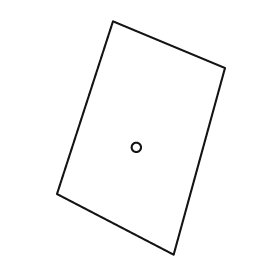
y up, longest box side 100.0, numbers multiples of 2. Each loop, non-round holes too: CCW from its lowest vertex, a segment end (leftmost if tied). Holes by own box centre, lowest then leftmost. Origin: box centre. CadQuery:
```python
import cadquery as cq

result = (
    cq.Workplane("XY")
    .moveTo(14.0, -50.0)
    .lineTo(36.0, 30.0)
    .lineTo(-12.0, 50.0)
    .lineTo(-36.0, -24.0)
    .close()
    .moveTo(-2.0, -4.0)
    .circle(2.0)
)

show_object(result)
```